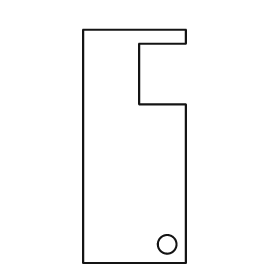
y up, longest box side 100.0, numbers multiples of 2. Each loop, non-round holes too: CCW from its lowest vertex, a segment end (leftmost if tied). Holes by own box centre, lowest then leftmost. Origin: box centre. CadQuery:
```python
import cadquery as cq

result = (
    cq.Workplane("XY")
    .moveTo(-22.0, -50.0)
    .lineTo(22.0, -50.0)
    .lineTo(22.0, 18.0)
    .lineTo(2.0, 18.0)
    .lineTo(2.0, 44.0)
    .lineTo(22.0, 44.0)
    .lineTo(22.0, 50.0)
    .lineTo(-22.0, 50.0)
    .close()
    .moveTo(14.0, -42.0)
    .circle(4.0)
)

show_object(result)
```